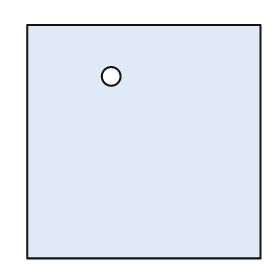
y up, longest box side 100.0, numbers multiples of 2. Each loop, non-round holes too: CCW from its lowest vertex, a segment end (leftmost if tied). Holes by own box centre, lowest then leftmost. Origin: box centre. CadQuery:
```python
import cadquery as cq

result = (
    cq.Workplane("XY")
    .moveTo(-50.0, -50.0)
    .lineTo(50.0, -50.0)
    .lineTo(50.0, 50.0)
    .lineTo(-50.0, 50.0)
    .close()
    .moveTo(-14.0, 28.0)
    .circle(4.0)
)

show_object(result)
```